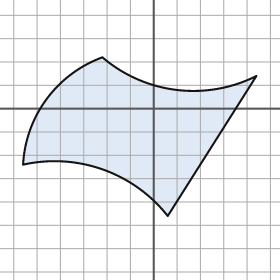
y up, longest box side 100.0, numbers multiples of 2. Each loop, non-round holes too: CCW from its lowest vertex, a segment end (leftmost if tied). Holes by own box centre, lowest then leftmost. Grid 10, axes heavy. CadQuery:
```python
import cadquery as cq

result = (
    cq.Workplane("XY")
    .moveTo(6.0, -46.0)
    .lineTo(44.0, 14.0)
    .threePointArc((10.0, 8.0), (-22.0, 22.0))
    .threePointArc((-46.0, 4.0), (-56.0, -24.0))
    .threePointArc((-22.0, -26.0), (6.0, -46.0))
    .close()
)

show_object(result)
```